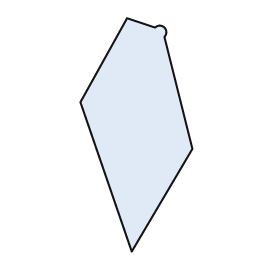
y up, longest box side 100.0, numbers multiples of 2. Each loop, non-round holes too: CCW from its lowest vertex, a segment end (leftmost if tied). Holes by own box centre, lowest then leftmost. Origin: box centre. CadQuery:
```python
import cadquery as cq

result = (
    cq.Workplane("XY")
    .moveTo(-2.0, -50.0)
    .lineTo(24.0, -6.0)
    .lineTo(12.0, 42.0)
    .threePointArc((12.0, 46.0), (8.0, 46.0))
    .lineTo(-4.0, 50.0)
    .lineTo(-24.0, 14.0)
    .close()
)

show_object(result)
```